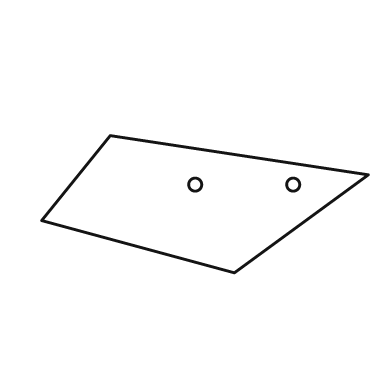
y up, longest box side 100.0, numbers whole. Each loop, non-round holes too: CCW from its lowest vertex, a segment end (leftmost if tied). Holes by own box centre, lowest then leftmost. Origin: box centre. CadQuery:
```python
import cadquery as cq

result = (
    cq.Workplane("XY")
    .moveTo(9.0, -21.0)
    .lineTo(50.0, 9.0)
    .lineTo(-29.0, 21.0)
    .lineTo(-50.0, -5.0)
    .close()
    .moveTo(-3.0, 6.0)
    .circle(2.0)
    .moveTo(27.0, 6.0)
    .circle(2.0)
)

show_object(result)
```